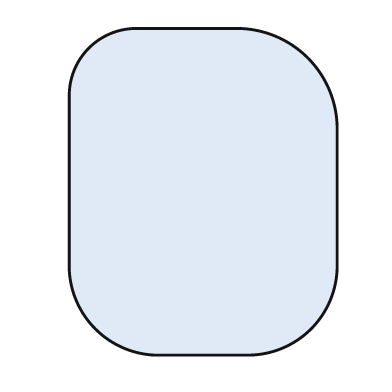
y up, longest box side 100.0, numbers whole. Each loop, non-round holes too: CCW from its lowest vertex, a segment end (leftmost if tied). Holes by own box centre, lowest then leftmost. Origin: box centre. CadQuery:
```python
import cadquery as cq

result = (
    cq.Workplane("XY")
    .moveTo(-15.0, -50.0)
    .lineTo(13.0, -50.0)
    .threePointArc((33.0, -42.0), (41.0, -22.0))
    .lineTo(41.0, 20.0)
    .threePointArc((32.0, 41.0), (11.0, 50.0))
    .lineTo(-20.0, 50.0)
    .threePointArc((-35.0, 44.0), (-41.0, 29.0))
    .lineTo(-41.0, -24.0)
    .threePointArc((-33.0, -42.0), (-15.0, -50.0))
    .close()
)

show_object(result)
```